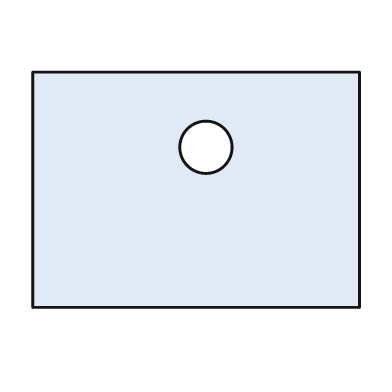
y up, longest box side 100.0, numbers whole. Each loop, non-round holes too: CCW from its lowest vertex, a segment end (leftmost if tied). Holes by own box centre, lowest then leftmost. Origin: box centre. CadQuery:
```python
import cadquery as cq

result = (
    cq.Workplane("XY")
    .moveTo(-50.0, -36.0)
    .lineTo(50.0, -36.0)
    .lineTo(50.0, 36.0)
    .lineTo(-50.0, 36.0)
    .close()
    .moveTo(3.0, 13.0)
    .circle(8.0)
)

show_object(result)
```